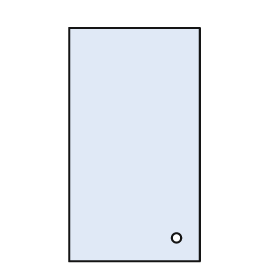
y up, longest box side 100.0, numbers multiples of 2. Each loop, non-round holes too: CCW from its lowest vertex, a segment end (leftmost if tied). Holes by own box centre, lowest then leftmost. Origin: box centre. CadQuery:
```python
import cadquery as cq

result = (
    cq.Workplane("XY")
    .moveTo(-28.0, -50.0)
    .lineTo(28.0, -50.0)
    .lineTo(28.0, 50.0)
    .lineTo(-28.0, 50.0)
    .close()
    .moveTo(18.0, -40.0)
    .circle(2.0)
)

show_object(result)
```